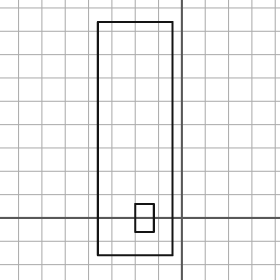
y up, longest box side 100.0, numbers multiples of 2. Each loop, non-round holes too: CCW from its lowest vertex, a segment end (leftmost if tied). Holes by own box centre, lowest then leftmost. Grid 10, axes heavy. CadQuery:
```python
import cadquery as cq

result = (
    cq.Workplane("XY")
    .moveTo(-36.0, -16.0)
    .lineTo(-4.0, -16.0)
    .lineTo(-4.0, 84.0)
    .lineTo(-36.0, 84.0)
    .close()
    .moveTo(-20.0, -6.0)
    .lineTo(-12.0, -6.0)
    .lineTo(-12.0, 6.0)
    .lineTo(-20.0, 6.0)
    .close()
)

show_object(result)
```